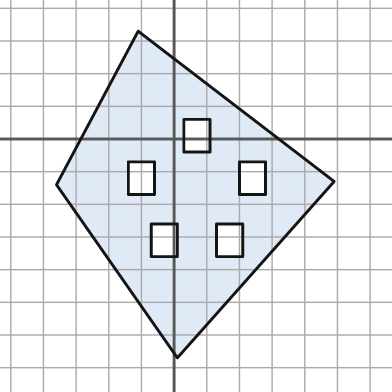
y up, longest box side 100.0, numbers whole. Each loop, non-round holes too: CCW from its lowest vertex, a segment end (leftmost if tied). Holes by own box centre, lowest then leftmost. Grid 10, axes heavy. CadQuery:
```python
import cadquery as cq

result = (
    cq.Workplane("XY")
    .moveTo(1.0, -67.0)
    .lineTo(49.0, -13.0)
    .lineTo(-11.0, 33.0)
    .lineTo(-36.0, -14.0)
    .close()
    .moveTo(-7.0, -36.0)
    .lineTo(1.0, -36.0)
    .lineTo(1.0, -26.0)
    .lineTo(-7.0, -26.0)
    .close()
    .moveTo(13.0, -36.0)
    .lineTo(21.0, -36.0)
    .lineTo(21.0, -26.0)
    .lineTo(13.0, -26.0)
    .close()
    .moveTo(-14.0, -17.0)
    .lineTo(-6.0, -17.0)
    .lineTo(-6.0, -7.0)
    .lineTo(-14.0, -7.0)
    .close()
    .moveTo(20.0, -17.0)
    .lineTo(28.0, -17.0)
    .lineTo(28.0, -7.0)
    .lineTo(20.0, -7.0)
    .close()
    .moveTo(3.0, -4.0)
    .lineTo(11.0, -4.0)
    .lineTo(11.0, 6.0)
    .lineTo(3.0, 6.0)
    .close()
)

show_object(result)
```